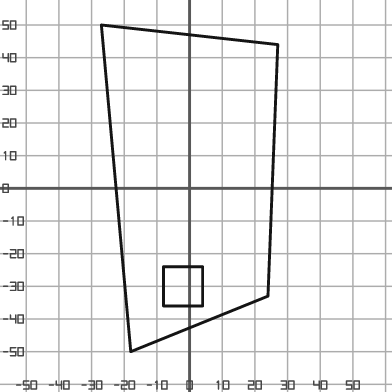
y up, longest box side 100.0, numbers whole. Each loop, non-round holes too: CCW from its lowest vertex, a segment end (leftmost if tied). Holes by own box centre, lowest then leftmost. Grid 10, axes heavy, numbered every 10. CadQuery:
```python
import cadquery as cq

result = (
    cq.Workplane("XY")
    .moveTo(-18.0, -50.0)
    .lineTo(24.0, -33.0)
    .lineTo(27.0, 44.0)
    .lineTo(-27.0, 50.0)
    .close()
    .moveTo(-8.0, -36.0)
    .lineTo(4.0, -36.0)
    .lineTo(4.0, -24.0)
    .lineTo(-8.0, -24.0)
    .close()
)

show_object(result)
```